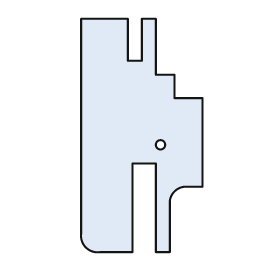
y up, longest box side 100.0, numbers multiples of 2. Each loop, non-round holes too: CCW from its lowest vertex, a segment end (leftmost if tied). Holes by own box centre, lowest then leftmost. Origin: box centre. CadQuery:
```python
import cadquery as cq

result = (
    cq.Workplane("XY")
    .moveTo(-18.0, -50.0)
    .lineTo(-4.0, -50.0)
    .lineTo(-4.0, -12.0)
    .lineTo(6.0, -12.0)
    .lineTo(6.0, -50.0)
    .lineTo(12.0, -50.0)
    .lineTo(12.0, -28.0)
    .threePointArc((14.0, -24.0), (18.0, -22.0))
    .lineTo(26.0, -22.0)
    .lineTo(26.0, 16.0)
    .lineTo(14.0, 16.0)
    .lineTo(14.0, 26.0)
    .lineTo(6.0, 26.0)
    .lineTo(6.0, 50.0)
    .lineTo(0.0, 50.0)
    .lineTo(0.0, 32.0)
    .lineTo(-6.0, 32.0)
    .lineTo(-6.0, 50.0)
    .lineTo(-26.0, 50.0)
    .lineTo(-26.0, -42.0)
    .threePointArc((-24.0, -48.0), (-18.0, -50.0))
    .close()
    .moveTo(8.0, -4.0)
    .circle(2.0)
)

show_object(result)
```